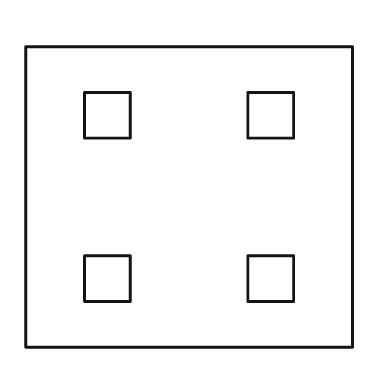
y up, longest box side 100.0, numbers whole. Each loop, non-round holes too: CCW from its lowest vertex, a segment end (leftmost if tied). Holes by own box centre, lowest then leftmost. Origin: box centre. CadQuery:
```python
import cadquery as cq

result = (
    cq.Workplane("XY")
    .moveTo(-50.0, -46.0)
    .lineTo(50.0, -46.0)
    .lineTo(50.0, 46.0)
    .lineTo(-50.0, 46.0)
    .close()
    .moveTo(-32.0, -32.0)
    .lineTo(-18.0, -32.0)
    .lineTo(-18.0, -18.0)
    .lineTo(-32.0, -18.0)
    .close()
    .moveTo(18.0, -32.0)
    .lineTo(32.0, -32.0)
    .lineTo(32.0, -18.0)
    .lineTo(18.0, -18.0)
    .close()
    .moveTo(-32.0, 18.0)
    .lineTo(-18.0, 18.0)
    .lineTo(-18.0, 32.0)
    .lineTo(-32.0, 32.0)
    .close()
    .moveTo(18.0, 18.0)
    .lineTo(32.0, 18.0)
    .lineTo(32.0, 32.0)
    .lineTo(18.0, 32.0)
    .close()
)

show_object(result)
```